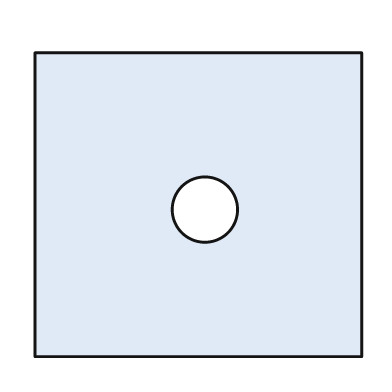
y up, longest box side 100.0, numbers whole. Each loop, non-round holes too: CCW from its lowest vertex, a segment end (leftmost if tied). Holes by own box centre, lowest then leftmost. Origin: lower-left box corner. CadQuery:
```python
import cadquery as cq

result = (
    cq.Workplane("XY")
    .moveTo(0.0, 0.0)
    .lineTo(100.0, 0.0)
    .lineTo(100.0, 93.0)
    .lineTo(0.0, 93.0)
    .close()
    .moveTo(52.0, 45.0)
    .circle(10.0)
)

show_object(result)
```